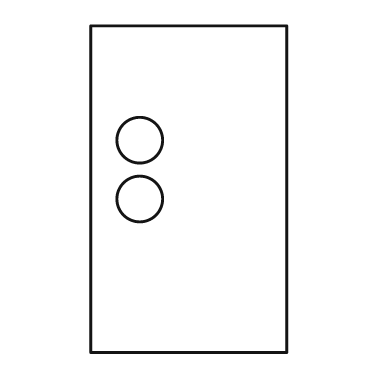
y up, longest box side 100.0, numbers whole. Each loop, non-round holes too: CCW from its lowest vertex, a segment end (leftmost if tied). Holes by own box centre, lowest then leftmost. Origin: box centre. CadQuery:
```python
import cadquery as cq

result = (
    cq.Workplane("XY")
    .moveTo(-30.0, -50.0)
    .lineTo(30.0, -50.0)
    .lineTo(30.0, 50.0)
    .lineTo(-30.0, 50.0)
    .close()
    .moveTo(-15.0, -3.0)
    .circle(7.0)
    .moveTo(-15.0, 15.0)
    .circle(7.0)
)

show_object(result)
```